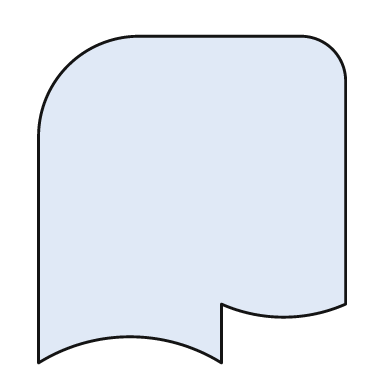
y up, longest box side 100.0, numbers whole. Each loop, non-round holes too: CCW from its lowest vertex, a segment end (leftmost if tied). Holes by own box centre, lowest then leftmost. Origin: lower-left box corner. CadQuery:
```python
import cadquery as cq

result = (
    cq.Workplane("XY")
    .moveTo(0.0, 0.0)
    .threePointArc((28.0, 8.0), (56.0, 0.0))
    .lineTo(56.0, 18.0)
    .threePointArc((75.0, 14.0), (94.0, 18.0))
    .lineTo(94.0, 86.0)
    .threePointArc((90.0, 96.0), (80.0, 100.0))
    .lineTo(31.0, 100.0)
    .threePointArc((9.0, 91.0), (0.0, 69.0))
    .close()
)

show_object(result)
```